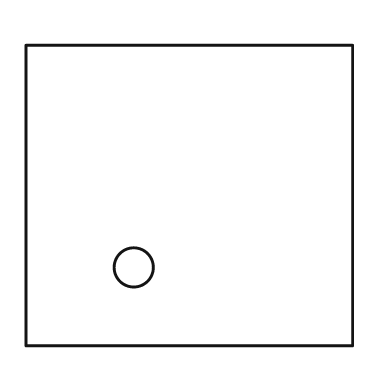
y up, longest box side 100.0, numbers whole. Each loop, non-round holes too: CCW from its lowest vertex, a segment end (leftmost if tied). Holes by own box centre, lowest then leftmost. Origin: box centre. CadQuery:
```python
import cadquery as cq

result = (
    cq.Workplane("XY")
    .moveTo(-50.0, -46.0)
    .lineTo(50.0, -46.0)
    .lineTo(50.0, 46.0)
    .lineTo(-50.0, 46.0)
    .close()
    .moveTo(-17.0, -22.0)
    .circle(6.0)
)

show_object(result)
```